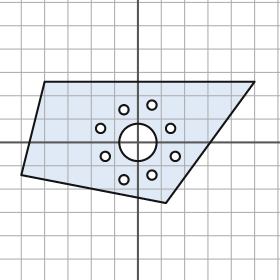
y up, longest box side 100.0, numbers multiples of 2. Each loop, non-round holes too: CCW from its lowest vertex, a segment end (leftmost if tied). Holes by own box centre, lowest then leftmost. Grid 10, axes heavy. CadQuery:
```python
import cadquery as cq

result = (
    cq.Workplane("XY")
    .moveTo(12.0, -26.0)
    .lineTo(50.0, 26.0)
    .lineTo(-40.0, 26.0)
    .lineTo(-50.0, -14.0)
    .close()
    .moveTo(-6.0, -16.0)
    .circle(2.0)
    .moveTo(6.0, -14.0)
    .circle(2.0)
    .moveTo(-14.0, -6.0)
    .circle(2.0)
    .moveTo(16.0, -6.0)
    .circle(2.0)
    .moveTo(0.0, 0.0)
    .circle(8.0)
    .moveTo(-16.0, 6.0)
    .circle(2.0)
    .moveTo(14.0, 6.0)
    .circle(2.0)
    .moveTo(-6.0, 14.0)
    .circle(2.0)
    .moveTo(6.0, 16.0)
    .circle(2.0)
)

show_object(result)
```